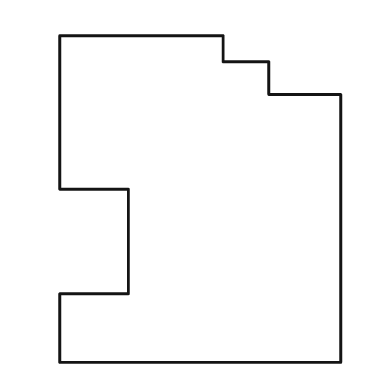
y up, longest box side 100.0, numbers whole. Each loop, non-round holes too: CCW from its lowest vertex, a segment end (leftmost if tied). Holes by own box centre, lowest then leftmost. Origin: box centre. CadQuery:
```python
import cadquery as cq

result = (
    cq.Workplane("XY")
    .moveTo(-43.0, -50.0)
    .lineTo(43.0, -50.0)
    .lineTo(43.0, 32.0)
    .lineTo(21.0, 32.0)
    .lineTo(21.0, 42.0)
    .lineTo(7.0, 42.0)
    .lineTo(7.0, 50.0)
    .lineTo(-43.0, 50.0)
    .lineTo(-43.0, 3.0)
    .lineTo(-22.0, 3.0)
    .lineTo(-22.0, -29.0)
    .lineTo(-43.0, -29.0)
    .close()
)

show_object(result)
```